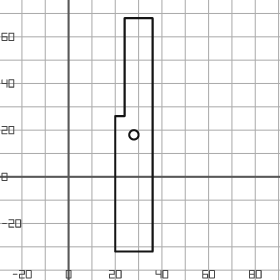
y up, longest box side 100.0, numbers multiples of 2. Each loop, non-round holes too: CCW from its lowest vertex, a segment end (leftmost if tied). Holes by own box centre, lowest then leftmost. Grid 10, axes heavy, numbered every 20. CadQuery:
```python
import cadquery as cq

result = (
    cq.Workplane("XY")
    .moveTo(20.0, -32.0)
    .lineTo(36.0, -32.0)
    .lineTo(36.0, 68.0)
    .lineTo(24.0, 68.0)
    .lineTo(24.0, 26.0)
    .lineTo(20.0, 26.0)
    .close()
    .moveTo(28.0, 18.0)
    .circle(2.0)
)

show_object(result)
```